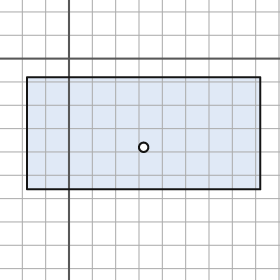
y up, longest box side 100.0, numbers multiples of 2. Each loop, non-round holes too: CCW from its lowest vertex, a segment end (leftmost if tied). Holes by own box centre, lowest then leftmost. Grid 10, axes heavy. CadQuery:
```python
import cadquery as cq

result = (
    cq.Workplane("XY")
    .moveTo(-18.0, -56.0)
    .lineTo(82.0, -56.0)
    .lineTo(82.0, -8.0)
    .lineTo(-18.0, -8.0)
    .close()
    .moveTo(32.0, -38.0)
    .circle(2.0)
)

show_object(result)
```